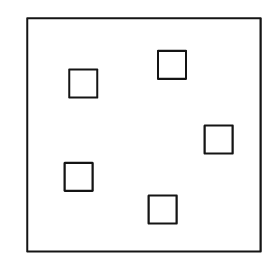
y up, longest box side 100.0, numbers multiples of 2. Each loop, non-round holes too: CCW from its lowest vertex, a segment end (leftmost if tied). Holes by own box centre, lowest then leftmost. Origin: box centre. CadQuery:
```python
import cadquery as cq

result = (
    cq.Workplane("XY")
    .moveTo(-50.0, -50.0)
    .lineTo(50.0, -50.0)
    .lineTo(50.0, 50.0)
    .lineTo(-50.0, 50.0)
    .close()
    .moveTo(2.0, -38.0)
    .lineTo(14.0, -38.0)
    .lineTo(14.0, -26.0)
    .lineTo(2.0, -26.0)
    .close()
    .moveTo(-34.0, -24.0)
    .lineTo(-22.0, -24.0)
    .lineTo(-22.0, -12.0)
    .lineTo(-34.0, -12.0)
    .close()
    .moveTo(26.0, -8.0)
    .lineTo(38.0, -8.0)
    .lineTo(38.0, 4.0)
    .lineTo(26.0, 4.0)
    .close()
    .moveTo(-32.0, 16.0)
    .lineTo(-20.0, 16.0)
    .lineTo(-20.0, 28.0)
    .lineTo(-32.0, 28.0)
    .close()
    .moveTo(6.0, 24.0)
    .lineTo(18.0, 24.0)
    .lineTo(18.0, 36.0)
    .lineTo(6.0, 36.0)
    .close()
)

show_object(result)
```